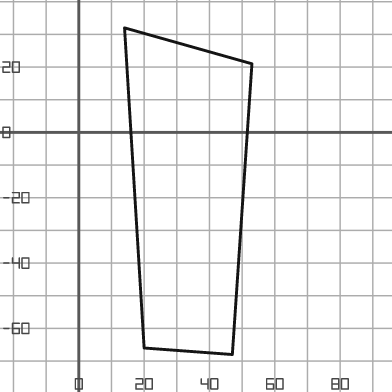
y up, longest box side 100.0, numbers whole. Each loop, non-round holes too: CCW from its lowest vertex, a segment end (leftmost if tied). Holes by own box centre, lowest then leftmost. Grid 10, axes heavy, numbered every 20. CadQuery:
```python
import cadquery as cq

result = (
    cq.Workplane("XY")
    .moveTo(47.0, -68.0)
    .lineTo(53.0, 21.0)
    .lineTo(14.0, 32.0)
    .lineTo(20.0, -66.0)
    .close()
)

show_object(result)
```